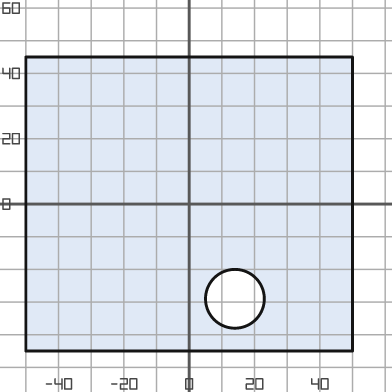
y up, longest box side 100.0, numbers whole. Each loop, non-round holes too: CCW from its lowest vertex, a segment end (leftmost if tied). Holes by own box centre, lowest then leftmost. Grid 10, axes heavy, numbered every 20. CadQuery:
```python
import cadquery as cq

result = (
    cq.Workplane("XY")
    .moveTo(-50.0, -45.0)
    .lineTo(50.0, -45.0)
    .lineTo(50.0, 45.0)
    .lineTo(-50.0, 45.0)
    .close()
    .moveTo(14.0, -29.0)
    .circle(9.0)
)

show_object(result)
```